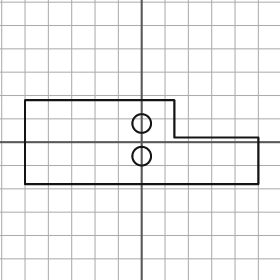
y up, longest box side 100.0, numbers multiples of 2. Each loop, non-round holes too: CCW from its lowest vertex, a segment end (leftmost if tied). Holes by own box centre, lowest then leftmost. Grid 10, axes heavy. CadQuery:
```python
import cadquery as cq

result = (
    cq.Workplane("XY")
    .moveTo(-50.0, -18.0)
    .lineTo(50.0, -18.0)
    .lineTo(50.0, 2.0)
    .lineTo(14.0, 2.0)
    .lineTo(14.0, 18.0)
    .lineTo(-50.0, 18.0)
    .close()
    .moveTo(0.0, -6.0)
    .circle(4.0)
    .moveTo(0.0, 8.0)
    .circle(4.0)
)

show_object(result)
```